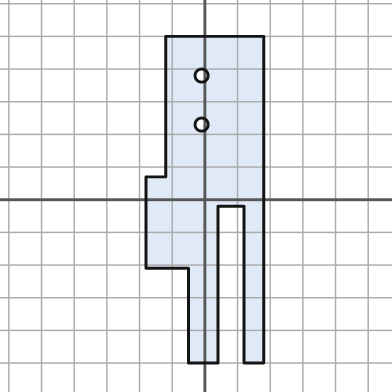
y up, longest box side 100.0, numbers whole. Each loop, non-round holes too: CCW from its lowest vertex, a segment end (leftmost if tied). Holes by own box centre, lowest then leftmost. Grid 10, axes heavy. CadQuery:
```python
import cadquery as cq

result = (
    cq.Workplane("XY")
    .moveTo(-5.0, -50.0)
    .lineTo(4.0, -50.0)
    .lineTo(4.0, -2.0)
    .lineTo(12.0, -2.0)
    .lineTo(12.0, -50.0)
    .lineTo(18.0, -50.0)
    .lineTo(18.0, 50.0)
    .lineTo(-12.0, 50.0)
    .lineTo(-12.0, 7.0)
    .lineTo(-18.0, 7.0)
    .lineTo(-18.0, -21.0)
    .lineTo(-5.0, -21.0)
    .close()
    .moveTo(-1.0, 23.0)
    .circle(2.0)
    .moveTo(-1.0, 38.0)
    .circle(2.0)
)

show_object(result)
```